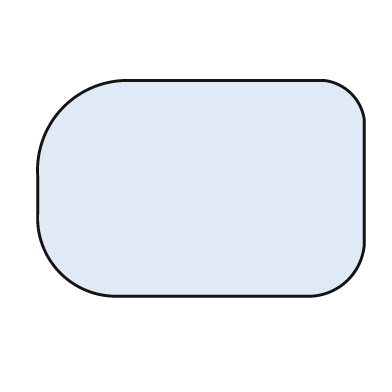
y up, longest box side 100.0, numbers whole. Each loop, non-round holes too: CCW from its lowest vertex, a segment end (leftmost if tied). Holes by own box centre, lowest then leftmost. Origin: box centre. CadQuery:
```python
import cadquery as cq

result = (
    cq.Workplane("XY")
    .moveTo(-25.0, -33.0)
    .lineTo(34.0, -33.0)
    .threePointArc((45.0, -28.0), (50.0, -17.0))
    .lineTo(50.0, 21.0)
    .threePointArc((46.0, 29.0), (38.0, 33.0))
    .lineTo(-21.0, 33.0)
    .threePointArc((-42.0, 25.0), (-50.0, 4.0))
    .lineTo(-50.0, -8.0)
    .threePointArc((-43.0, -26.0), (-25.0, -33.0))
    .close()
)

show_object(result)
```